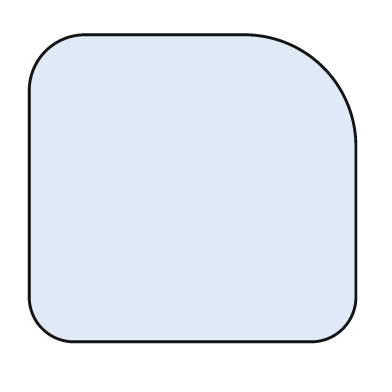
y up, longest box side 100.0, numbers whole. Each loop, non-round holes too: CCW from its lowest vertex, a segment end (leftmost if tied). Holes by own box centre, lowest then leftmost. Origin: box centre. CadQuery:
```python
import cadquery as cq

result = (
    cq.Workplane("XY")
    .moveTo(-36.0, -47.0)
    .lineTo(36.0, -47.0)
    .threePointArc((46.0, -43.0), (50.0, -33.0))
    .lineTo(50.0, 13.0)
    .threePointArc((40.0, 37.0), (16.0, 47.0))
    .lineTo(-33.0, 47.0)
    .threePointArc((-45.0, 42.0), (-50.0, 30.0))
    .lineTo(-50.0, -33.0)
    .threePointArc((-46.0, -43.0), (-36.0, -47.0))
    .close()
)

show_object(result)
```